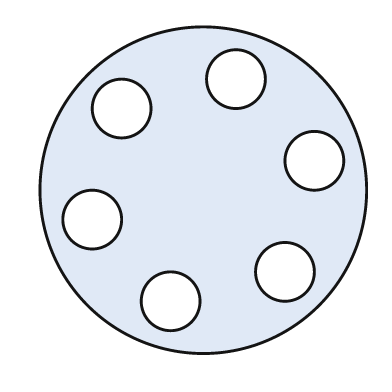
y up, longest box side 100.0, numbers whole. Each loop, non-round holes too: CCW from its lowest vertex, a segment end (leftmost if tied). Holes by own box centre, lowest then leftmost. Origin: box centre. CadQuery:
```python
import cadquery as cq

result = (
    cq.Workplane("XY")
    .moveTo(0.0, 0.0)
    .circle(50.0)
    .moveTo(-10.0, -34.0)
    .circle(9.0)
    .moveTo(25.0, -25.0)
    .circle(9.0)
    .moveTo(-34.0, -9.0)
    .circle(9.0)
    .moveTo(34.0, 9.0)
    .circle(9.0)
    .moveTo(-25.0, 25.0)
    .circle(9.0)
    .moveTo(10.0, 34.0)
    .circle(9.0)
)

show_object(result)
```